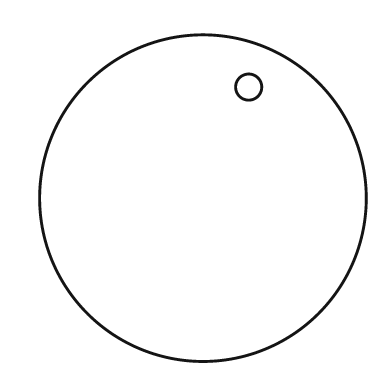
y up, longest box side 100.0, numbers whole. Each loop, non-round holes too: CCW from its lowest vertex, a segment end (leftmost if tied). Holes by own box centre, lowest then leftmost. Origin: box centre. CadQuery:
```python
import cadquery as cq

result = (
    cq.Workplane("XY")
    .moveTo(0.0, 0.0)
    .circle(50.0)
    .moveTo(14.0, 34.0)
    .circle(4.0)
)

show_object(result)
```